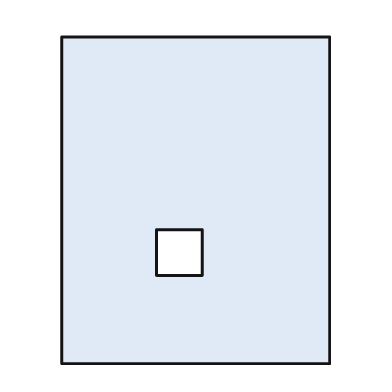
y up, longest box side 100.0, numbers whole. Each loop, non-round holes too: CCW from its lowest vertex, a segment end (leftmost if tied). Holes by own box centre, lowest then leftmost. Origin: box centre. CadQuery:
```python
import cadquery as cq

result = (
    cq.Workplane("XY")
    .moveTo(-41.0, -50.0)
    .lineTo(41.0, -50.0)
    .lineTo(41.0, 50.0)
    .lineTo(-41.0, 50.0)
    .close()
    .moveTo(-12.0, -23.0)
    .lineTo(2.0, -23.0)
    .lineTo(2.0, -9.0)
    .lineTo(-12.0, -9.0)
    .close()
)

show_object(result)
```